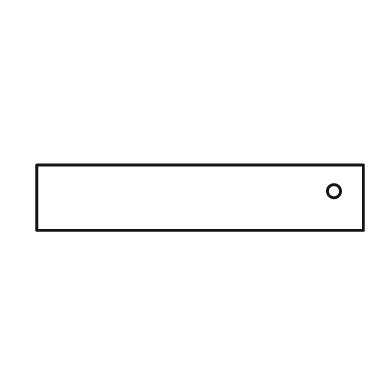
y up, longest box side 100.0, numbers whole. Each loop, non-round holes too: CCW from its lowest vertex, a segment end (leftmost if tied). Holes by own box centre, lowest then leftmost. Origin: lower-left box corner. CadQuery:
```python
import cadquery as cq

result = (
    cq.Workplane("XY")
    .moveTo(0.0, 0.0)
    .lineTo(100.0, 0.0)
    .lineTo(100.0, 20.0)
    .lineTo(0.0, 20.0)
    .close()
    .moveTo(91.0, 12.0)
    .circle(2.0)
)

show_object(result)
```